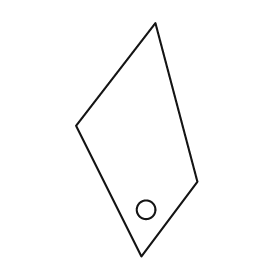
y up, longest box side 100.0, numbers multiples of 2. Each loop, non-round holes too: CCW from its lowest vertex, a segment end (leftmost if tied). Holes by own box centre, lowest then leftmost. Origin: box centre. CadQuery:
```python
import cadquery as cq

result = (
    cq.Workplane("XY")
    .moveTo(2.0, -50.0)
    .lineTo(26.0, -18.0)
    .lineTo(8.0, 50.0)
    .lineTo(-26.0, 6.0)
    .close()
    .moveTo(4.0, -30.0)
    .circle(4.0)
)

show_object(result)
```